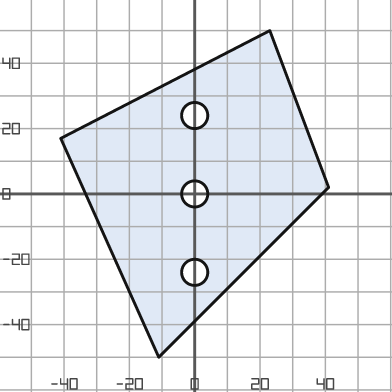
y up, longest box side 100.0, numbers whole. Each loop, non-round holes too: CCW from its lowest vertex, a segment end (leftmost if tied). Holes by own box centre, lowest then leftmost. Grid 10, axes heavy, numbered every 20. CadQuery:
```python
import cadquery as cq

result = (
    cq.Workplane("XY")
    .moveTo(-11.0, -50.0)
    .lineTo(41.0, 2.0)
    .lineTo(23.0, 50.0)
    .lineTo(-41.0, 17.0)
    .close()
    .moveTo(0.0, -24.0)
    .circle(4.0)
    .moveTo(0.0, 0.0)
    .circle(4.0)
    .moveTo(0.0, 24.0)
    .circle(4.0)
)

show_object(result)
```